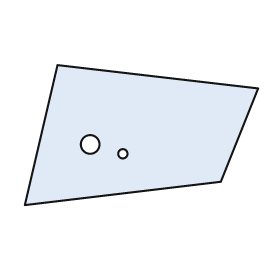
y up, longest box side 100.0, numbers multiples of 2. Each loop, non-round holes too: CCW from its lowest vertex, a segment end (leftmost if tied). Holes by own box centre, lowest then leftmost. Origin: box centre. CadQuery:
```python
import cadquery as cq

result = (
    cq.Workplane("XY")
    .moveTo(-50.0, -30.0)
    .lineTo(34.0, -20.0)
    .lineTo(50.0, 20.0)
    .lineTo(-36.0, 30.0)
    .close()
    .moveTo(-8.0, -8.0)
    .circle(2.0)
    .moveTo(-22.0, -4.0)
    .circle(4.0)
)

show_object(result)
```